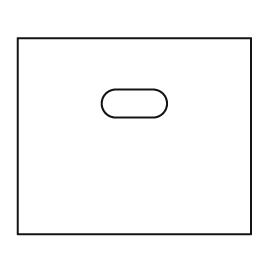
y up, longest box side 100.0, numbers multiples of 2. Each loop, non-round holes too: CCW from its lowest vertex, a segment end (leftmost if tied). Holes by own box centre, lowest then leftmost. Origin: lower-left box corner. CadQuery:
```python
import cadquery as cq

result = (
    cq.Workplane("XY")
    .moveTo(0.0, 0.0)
    .lineTo(100.0, 0.0)
    .lineTo(100.0, 84.0)
    .lineTo(0.0, 84.0)
    .close()
    .moveTo(42.0, 50.0)
    .lineTo(58.0, 50.0)
    .threePointArc((64.0, 56.0), (58.0, 62.0))
    .lineTo(42.0, 62.0)
    .threePointArc((36.0, 56.0), (42.0, 50.0))
    .close()
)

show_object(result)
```